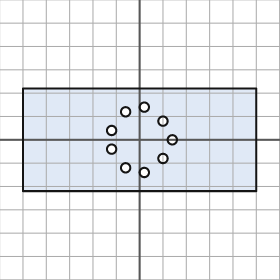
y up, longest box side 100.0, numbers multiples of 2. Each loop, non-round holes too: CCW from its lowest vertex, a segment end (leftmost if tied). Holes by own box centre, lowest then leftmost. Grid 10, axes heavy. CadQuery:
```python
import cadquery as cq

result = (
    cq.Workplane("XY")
    .moveTo(-50.0, -22.0)
    .lineTo(50.0, -22.0)
    .lineTo(50.0, 22.0)
    .lineTo(-50.0, 22.0)
    .close()
    .moveTo(2.0, -14.0)
    .circle(2.0)
    .moveTo(-6.0, -12.0)
    .circle(2.0)
    .moveTo(10.0, -8.0)
    .circle(2.0)
    .moveTo(-12.0, -4.0)
    .circle(2.0)
    .moveTo(14.0, 0.0)
    .circle(2.0)
    .moveTo(-12.0, 4.0)
    .circle(2.0)
    .moveTo(10.0, 8.0)
    .circle(2.0)
    .moveTo(-6.0, 12.0)
    .circle(2.0)
    .moveTo(2.0, 14.0)
    .circle(2.0)
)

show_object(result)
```